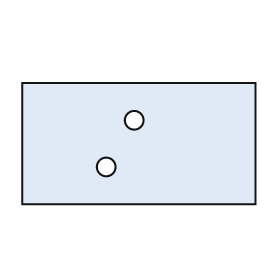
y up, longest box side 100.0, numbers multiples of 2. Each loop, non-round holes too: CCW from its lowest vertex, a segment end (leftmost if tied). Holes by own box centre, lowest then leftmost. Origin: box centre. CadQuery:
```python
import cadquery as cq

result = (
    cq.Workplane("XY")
    .moveTo(-50.0, -26.0)
    .lineTo(50.0, -26.0)
    .lineTo(50.0, 26.0)
    .lineTo(-50.0, 26.0)
    .close()
    .moveTo(-14.0, -10.0)
    .circle(4.0)
    .moveTo(-2.0, 10.0)
    .circle(4.0)
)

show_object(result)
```